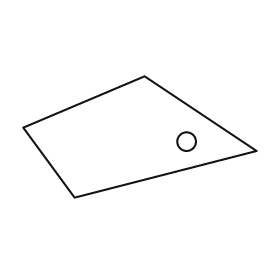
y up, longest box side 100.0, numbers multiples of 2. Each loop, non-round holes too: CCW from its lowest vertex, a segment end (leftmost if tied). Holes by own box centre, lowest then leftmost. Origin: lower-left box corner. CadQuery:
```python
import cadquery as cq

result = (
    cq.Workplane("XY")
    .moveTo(22.0, 0.0)
    .lineTo(100.0, 20.0)
    .lineTo(52.0, 52.0)
    .lineTo(0.0, 30.0)
    .close()
    .moveTo(70.0, 24.0)
    .circle(4.0)
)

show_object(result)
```